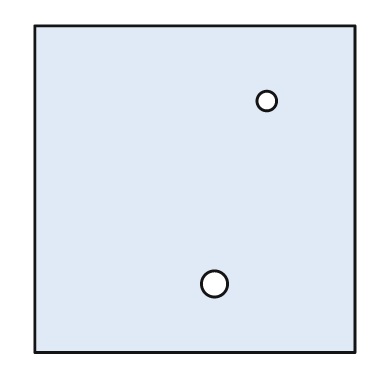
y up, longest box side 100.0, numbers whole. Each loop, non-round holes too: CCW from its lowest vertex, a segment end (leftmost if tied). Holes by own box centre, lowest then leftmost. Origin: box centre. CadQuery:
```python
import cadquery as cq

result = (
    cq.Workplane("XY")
    .moveTo(-49.0, -50.0)
    .lineTo(49.0, -50.0)
    .lineTo(49.0, 50.0)
    .lineTo(-49.0, 50.0)
    .close()
    .moveTo(6.0, -29.0)
    .circle(4.0)
    .moveTo(22.0, 27.0)
    .circle(3.0)
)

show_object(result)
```